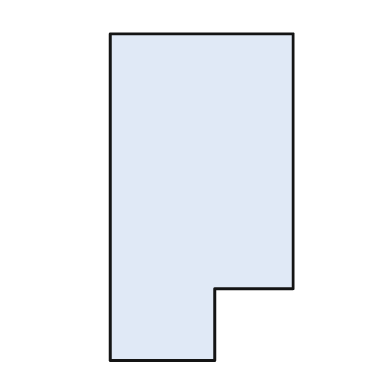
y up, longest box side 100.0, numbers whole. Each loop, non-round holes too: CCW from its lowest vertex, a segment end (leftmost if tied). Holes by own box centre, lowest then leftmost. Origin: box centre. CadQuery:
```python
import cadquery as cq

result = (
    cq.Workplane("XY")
    .moveTo(-28.0, -50.0)
    .lineTo(4.0, -50.0)
    .lineTo(4.0, -28.0)
    .lineTo(28.0, -28.0)
    .lineTo(28.0, 50.0)
    .lineTo(-28.0, 50.0)
    .close()
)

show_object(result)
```